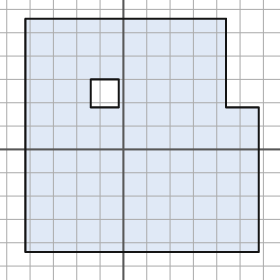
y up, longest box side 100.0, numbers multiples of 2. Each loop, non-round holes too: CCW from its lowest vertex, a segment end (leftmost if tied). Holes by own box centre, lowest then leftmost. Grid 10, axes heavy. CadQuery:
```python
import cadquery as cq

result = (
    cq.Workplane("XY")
    .moveTo(-42.0, -44.0)
    .lineTo(58.0, -44.0)
    .lineTo(58.0, 18.0)
    .lineTo(44.0, 18.0)
    .lineTo(44.0, 56.0)
    .lineTo(-42.0, 56.0)
    .close()
    .moveTo(-14.0, 18.0)
    .lineTo(-2.0, 18.0)
    .lineTo(-2.0, 30.0)
    .lineTo(-14.0, 30.0)
    .close()
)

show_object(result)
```